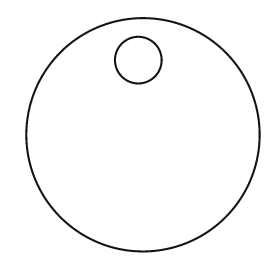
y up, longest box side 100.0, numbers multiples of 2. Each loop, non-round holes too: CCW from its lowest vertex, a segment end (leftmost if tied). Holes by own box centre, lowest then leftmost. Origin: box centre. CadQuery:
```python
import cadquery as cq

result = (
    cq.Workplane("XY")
    .moveTo(0.0, 0.0)
    .circle(50.0)
    .moveTo(-2.0, 32.0)
    .circle(10.0)
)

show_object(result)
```